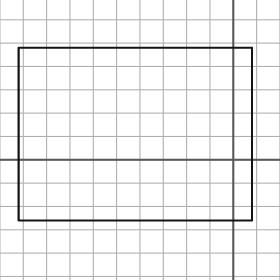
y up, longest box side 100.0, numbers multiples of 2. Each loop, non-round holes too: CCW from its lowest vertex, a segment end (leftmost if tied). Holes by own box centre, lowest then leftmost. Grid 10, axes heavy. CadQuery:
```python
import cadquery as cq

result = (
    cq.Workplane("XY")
    .moveTo(-92.0, -26.0)
    .lineTo(8.0, -26.0)
    .lineTo(8.0, 48.0)
    .lineTo(-92.0, 48.0)
    .close()
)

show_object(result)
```